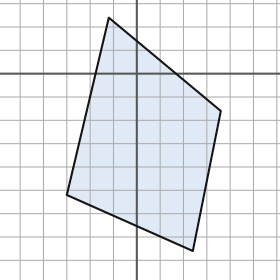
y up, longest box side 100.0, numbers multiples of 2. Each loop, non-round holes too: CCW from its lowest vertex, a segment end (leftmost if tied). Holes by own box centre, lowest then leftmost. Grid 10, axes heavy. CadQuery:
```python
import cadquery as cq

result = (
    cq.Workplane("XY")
    .moveTo(24.0, -76.0)
    .lineTo(36.0, -16.0)
    .lineTo(-12.0, 24.0)
    .lineTo(-30.0, -52.0)
    .close()
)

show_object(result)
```